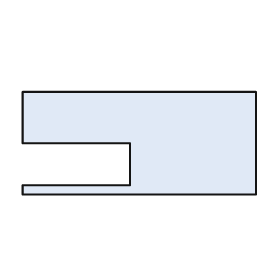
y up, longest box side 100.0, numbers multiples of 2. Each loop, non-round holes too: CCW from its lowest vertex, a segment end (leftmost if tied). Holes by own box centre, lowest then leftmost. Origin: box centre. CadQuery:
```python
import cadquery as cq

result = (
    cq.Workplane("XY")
    .moveTo(-50.0, -22.0)
    .lineTo(50.0, -22.0)
    .lineTo(50.0, 22.0)
    .lineTo(-50.0, 22.0)
    .lineTo(-50.0, 0.0)
    .lineTo(-4.0, 0.0)
    .lineTo(-4.0, -18.0)
    .lineTo(-50.0, -18.0)
    .close()
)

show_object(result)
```